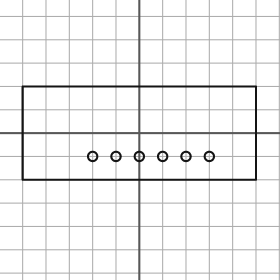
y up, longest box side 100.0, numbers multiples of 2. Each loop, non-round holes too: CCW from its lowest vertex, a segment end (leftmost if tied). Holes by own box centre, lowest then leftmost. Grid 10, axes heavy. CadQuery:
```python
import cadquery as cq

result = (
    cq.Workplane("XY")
    .moveTo(-50.0, -20.0)
    .lineTo(50.0, -20.0)
    .lineTo(50.0, 20.0)
    .lineTo(-50.0, 20.0)
    .close()
    .moveTo(-20.0, -10.0)
    .circle(2.0)
    .moveTo(-10.0, -10.0)
    .circle(2.0)
    .moveTo(0.0, -10.0)
    .circle(2.0)
    .moveTo(10.0, -10.0)
    .circle(2.0)
    .moveTo(20.0, -10.0)
    .circle(2.0)
    .moveTo(30.0, -10.0)
    .circle(2.0)
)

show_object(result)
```